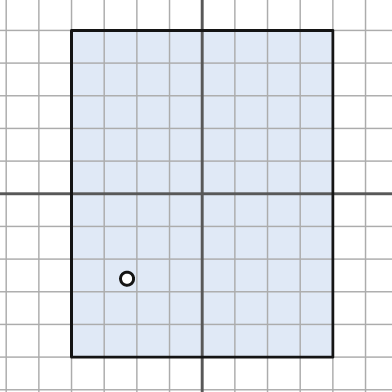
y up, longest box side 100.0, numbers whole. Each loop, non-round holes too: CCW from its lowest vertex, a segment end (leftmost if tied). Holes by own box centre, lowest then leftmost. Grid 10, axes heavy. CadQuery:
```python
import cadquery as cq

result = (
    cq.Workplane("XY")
    .moveTo(-40.0, -50.0)
    .lineTo(40.0, -50.0)
    .lineTo(40.0, 50.0)
    .lineTo(-40.0, 50.0)
    .close()
    .moveTo(-23.0, -26.0)
    .circle(2.0)
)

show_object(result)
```